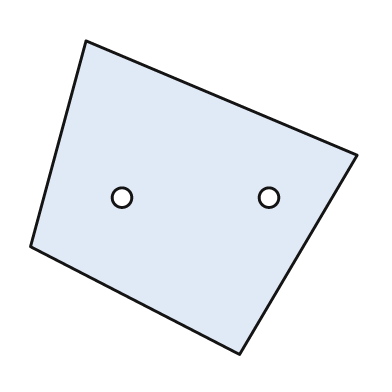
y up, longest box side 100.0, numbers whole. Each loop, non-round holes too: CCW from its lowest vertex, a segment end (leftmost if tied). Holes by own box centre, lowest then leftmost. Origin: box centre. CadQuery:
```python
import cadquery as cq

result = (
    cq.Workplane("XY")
    .moveTo(14.0, -48.0)
    .lineTo(50.0, 13.0)
    .lineTo(-33.0, 48.0)
    .lineTo(-50.0, -15.0)
    .close()
    .moveTo(-22.0, 0.0)
    .circle(3.0)
    .moveTo(23.0, 0.0)
    .circle(3.0)
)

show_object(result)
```